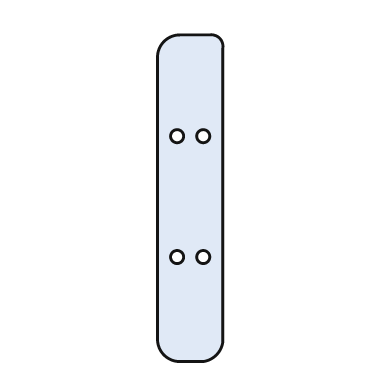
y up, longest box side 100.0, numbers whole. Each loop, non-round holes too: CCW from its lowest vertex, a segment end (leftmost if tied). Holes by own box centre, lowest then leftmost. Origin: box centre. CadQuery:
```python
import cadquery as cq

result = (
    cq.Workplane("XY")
    .moveTo(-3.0, -50.0)
    .lineTo(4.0, -50.0)
    .threePointArc((8.0, -48.0), (10.0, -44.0))
    .lineTo(10.0, 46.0)
    .threePointArc((9.0, 49.0), (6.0, 50.0))
    .lineTo(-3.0, 50.0)
    .threePointArc((-8.0, 48.0), (-10.0, 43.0))
    .lineTo(-10.0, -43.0)
    .threePointArc((-8.0, -48.0), (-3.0, -50.0))
    .close()
    .moveTo(-4.0, -18.0)
    .circle(2.0)
    .moveTo(4.0, -18.0)
    .circle(2.0)
    .moveTo(-4.0, 19.0)
    .circle(2.0)
    .moveTo(4.0, 19.0)
    .circle(2.0)
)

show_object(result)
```